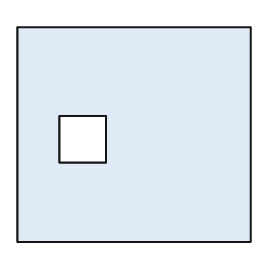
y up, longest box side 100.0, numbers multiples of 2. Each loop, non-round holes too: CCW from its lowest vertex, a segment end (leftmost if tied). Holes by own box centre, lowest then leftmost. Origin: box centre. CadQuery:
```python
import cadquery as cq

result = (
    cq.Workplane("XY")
    .moveTo(-50.0, -46.0)
    .lineTo(50.0, -46.0)
    .lineTo(50.0, 46.0)
    .lineTo(-50.0, 46.0)
    .close()
    .moveTo(-32.0, -12.0)
    .lineTo(-12.0, -12.0)
    .lineTo(-12.0, 8.0)
    .lineTo(-32.0, 8.0)
    .close()
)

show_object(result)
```